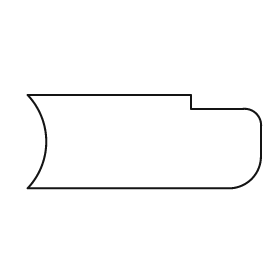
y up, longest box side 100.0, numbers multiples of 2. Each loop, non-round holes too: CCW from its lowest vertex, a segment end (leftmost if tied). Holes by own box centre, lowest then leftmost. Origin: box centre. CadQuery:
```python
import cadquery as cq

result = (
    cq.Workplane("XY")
    .moveTo(-50.0, -20.0)
    .lineTo(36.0, -20.0)
    .threePointArc((46.0, -16.0), (50.0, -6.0))
    .lineTo(50.0, 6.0)
    .threePointArc((48.0, 12.0), (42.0, 14.0))
    .lineTo(20.0, 14.0)
    .lineTo(20.0, 20.0)
    .lineTo(-50.0, 20.0)
    .threePointArc((-42.0, 0.0), (-50.0, -20.0))
    .close()
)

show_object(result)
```